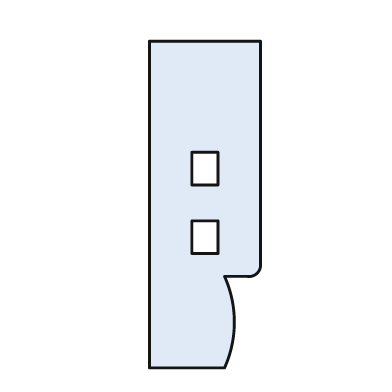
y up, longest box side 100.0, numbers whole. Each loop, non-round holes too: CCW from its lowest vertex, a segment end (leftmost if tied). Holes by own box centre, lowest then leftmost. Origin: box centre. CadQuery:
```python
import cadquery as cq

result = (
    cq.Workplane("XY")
    .moveTo(-17.0, -50.0)
    .lineTo(6.0, -50.0)
    .threePointArc((9.0, -36.0), (6.0, -22.0))
    .lineTo(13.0, -22.0)
    .threePointArc((16.0, -21.0), (17.0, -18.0))
    .lineTo(17.0, 50.0)
    .lineTo(-17.0, 50.0)
    .close()
    .moveTo(-4.0, -15.0)
    .lineTo(4.0, -15.0)
    .lineTo(4.0, -5.0)
    .lineTo(-4.0, -5.0)
    .close()
    .moveTo(-4.0, 6.0)
    .lineTo(4.0, 6.0)
    .lineTo(4.0, 16.0)
    .lineTo(-4.0, 16.0)
    .close()
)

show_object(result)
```